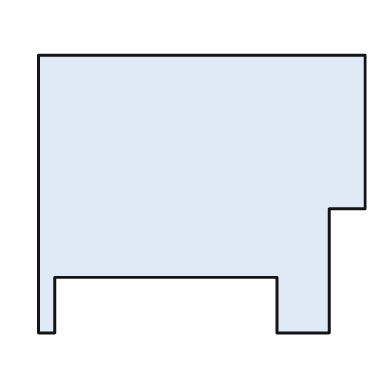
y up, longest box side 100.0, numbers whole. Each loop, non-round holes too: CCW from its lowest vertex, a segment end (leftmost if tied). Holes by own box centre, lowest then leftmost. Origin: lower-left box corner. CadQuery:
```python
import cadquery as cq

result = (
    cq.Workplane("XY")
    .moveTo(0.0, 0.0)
    .lineTo(5.0, 0.0)
    .lineTo(5.0, 17.0)
    .lineTo(73.0, 17.0)
    .lineTo(73.0, 0.0)
    .lineTo(89.0, 0.0)
    .lineTo(89.0, 38.0)
    .lineTo(100.0, 38.0)
    .lineTo(100.0, 85.0)
    .lineTo(0.0, 85.0)
    .close()
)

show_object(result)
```